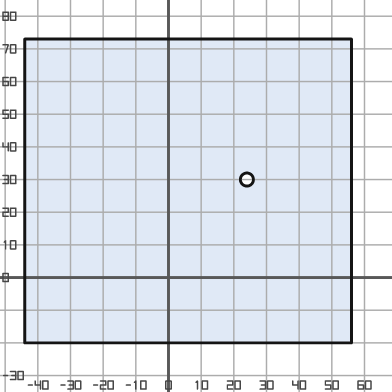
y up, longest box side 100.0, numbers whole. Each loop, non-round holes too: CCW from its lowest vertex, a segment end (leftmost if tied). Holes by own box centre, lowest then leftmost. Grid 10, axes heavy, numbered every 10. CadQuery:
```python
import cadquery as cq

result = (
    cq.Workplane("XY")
    .moveTo(-44.0, -20.0)
    .lineTo(56.0, -20.0)
    .lineTo(56.0, 73.0)
    .lineTo(-44.0, 73.0)
    .close()
    .moveTo(24.0, 30.0)
    .circle(2.0)
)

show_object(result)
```